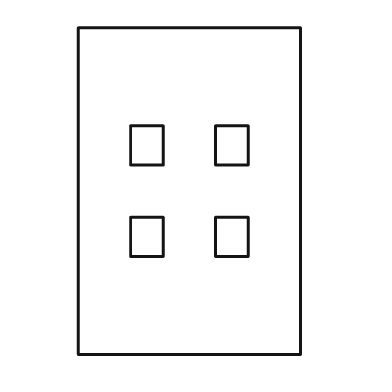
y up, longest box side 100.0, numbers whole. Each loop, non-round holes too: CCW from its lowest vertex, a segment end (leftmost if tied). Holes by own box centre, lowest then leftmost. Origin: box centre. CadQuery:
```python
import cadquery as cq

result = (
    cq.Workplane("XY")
    .moveTo(-34.0, -50.0)
    .lineTo(34.0, -50.0)
    .lineTo(34.0, 50.0)
    .lineTo(-34.0, 50.0)
    .close()
    .moveTo(-18.0, -20.0)
    .lineTo(-8.0, -20.0)
    .lineTo(-8.0, -8.0)
    .lineTo(-18.0, -8.0)
    .close()
    .moveTo(8.0, -20.0)
    .lineTo(18.0, -20.0)
    .lineTo(18.0, -8.0)
    .lineTo(8.0, -8.0)
    .close()
    .moveTo(-18.0, 8.0)
    .lineTo(-8.0, 8.0)
    .lineTo(-8.0, 20.0)
    .lineTo(-18.0, 20.0)
    .close()
    .moveTo(8.0, 8.0)
    .lineTo(18.0, 8.0)
    .lineTo(18.0, 20.0)
    .lineTo(8.0, 20.0)
    .close()
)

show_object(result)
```